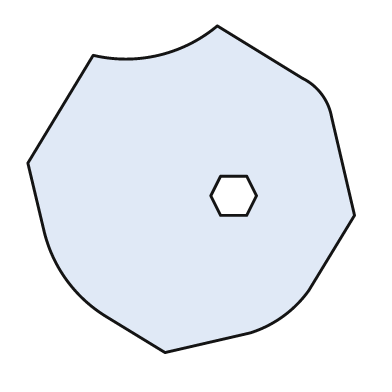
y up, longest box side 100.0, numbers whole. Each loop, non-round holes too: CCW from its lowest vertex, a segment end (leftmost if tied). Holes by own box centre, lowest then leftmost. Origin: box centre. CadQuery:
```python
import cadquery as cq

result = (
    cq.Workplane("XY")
    .moveTo(-8.0, -50.0)
    .lineTo(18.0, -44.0)
    .threePointArc((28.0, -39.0), (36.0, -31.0))
    .lineTo(50.0, -8.0)
    .lineTo(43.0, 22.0)
    .threePointArc((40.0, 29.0), (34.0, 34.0))
    .lineTo(8.0, 50.0)
    .threePointArc((-10.0, 41.0), (-30.0, 41.0))
    .lineTo(-50.0, 8.0)
    .lineTo(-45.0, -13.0)
    .threePointArc((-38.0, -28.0), (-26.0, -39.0))
    .close()
    .moveTo(9.0, -8.0)
    .lineTo(17.0, -8.0)
    .lineTo(20.0, -2.0)
    .lineTo(17.0, 4.0)
    .lineTo(9.0, 4.0)
    .lineTo(6.0, -2.0)
    .close()
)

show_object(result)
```